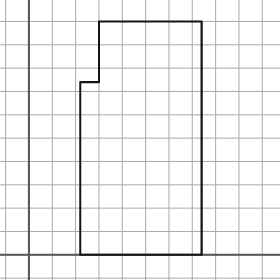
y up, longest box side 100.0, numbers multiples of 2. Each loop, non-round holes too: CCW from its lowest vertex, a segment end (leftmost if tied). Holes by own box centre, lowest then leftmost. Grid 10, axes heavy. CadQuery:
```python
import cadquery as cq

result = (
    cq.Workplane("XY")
    .moveTo(22.0, 0.0)
    .lineTo(74.0, 0.0)
    .lineTo(74.0, 100.0)
    .lineTo(30.0, 100.0)
    .lineTo(30.0, 74.0)
    .lineTo(22.0, 74.0)
    .close()
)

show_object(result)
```